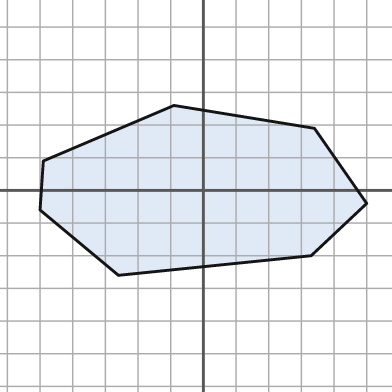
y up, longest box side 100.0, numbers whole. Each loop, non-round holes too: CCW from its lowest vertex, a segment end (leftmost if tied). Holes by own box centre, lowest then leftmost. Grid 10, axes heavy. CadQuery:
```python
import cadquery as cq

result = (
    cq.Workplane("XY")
    .moveTo(-26.0, -26.0)
    .lineTo(33.0, -20.0)
    .lineTo(50.0, -4.0)
    .lineTo(34.0, 19.0)
    .lineTo(-9.0, 26.0)
    .lineTo(-49.0, 9.0)
    .lineTo(-50.0, -6.0)
    .close()
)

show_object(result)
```